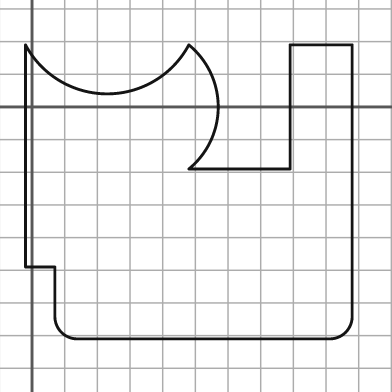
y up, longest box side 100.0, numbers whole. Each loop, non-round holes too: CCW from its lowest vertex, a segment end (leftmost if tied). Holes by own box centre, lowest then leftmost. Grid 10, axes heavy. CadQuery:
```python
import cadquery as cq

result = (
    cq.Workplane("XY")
    .moveTo(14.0, -71.0)
    .lineTo(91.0, -71.0)
    .threePointArc((96.0, -69.0), (98.0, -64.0))
    .lineTo(98.0, 19.0)
    .lineTo(79.0, 19.0)
    .lineTo(79.0, -19.0)
    .lineTo(48.0, -19.0)
    .threePointArc((57.0, 0.0), (48.0, 19.0))
    .threePointArc((23.0, 4.0), (-2.0, 19.0))
    .lineTo(-2.0, -49.0)
    .lineTo(7.0, -49.0)
    .lineTo(7.0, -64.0)
    .threePointArc((9.0, -69.0), (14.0, -71.0))
    .close()
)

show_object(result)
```